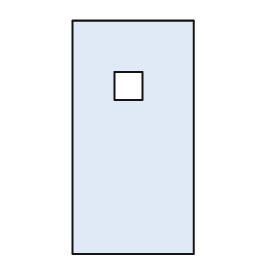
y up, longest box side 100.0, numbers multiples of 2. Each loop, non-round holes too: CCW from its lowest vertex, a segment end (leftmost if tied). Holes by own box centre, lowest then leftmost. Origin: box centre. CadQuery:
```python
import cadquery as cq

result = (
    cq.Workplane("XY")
    .moveTo(-26.0, -50.0)
    .lineTo(26.0, -50.0)
    .lineTo(26.0, 50.0)
    .lineTo(-26.0, 50.0)
    .close()
    .moveTo(-8.0, 16.0)
    .lineTo(4.0, 16.0)
    .lineTo(4.0, 28.0)
    .lineTo(-8.0, 28.0)
    .close()
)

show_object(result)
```